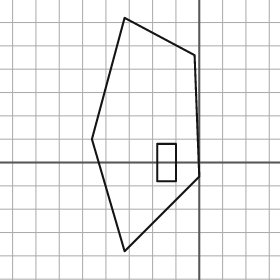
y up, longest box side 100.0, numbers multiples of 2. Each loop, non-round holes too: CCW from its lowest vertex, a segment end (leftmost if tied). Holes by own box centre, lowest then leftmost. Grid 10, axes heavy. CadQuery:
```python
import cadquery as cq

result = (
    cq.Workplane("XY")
    .moveTo(-32.0, -38.0)
    .lineTo(0.0, -6.0)
    .lineTo(-2.0, 46.0)
    .lineTo(-32.0, 62.0)
    .lineTo(-46.0, 10.0)
    .close()
    .moveTo(-18.0, -8.0)
    .lineTo(-10.0, -8.0)
    .lineTo(-10.0, 8.0)
    .lineTo(-18.0, 8.0)
    .close()
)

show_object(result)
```